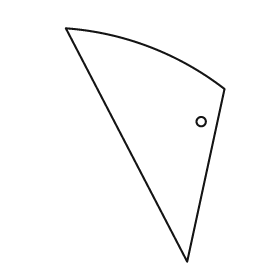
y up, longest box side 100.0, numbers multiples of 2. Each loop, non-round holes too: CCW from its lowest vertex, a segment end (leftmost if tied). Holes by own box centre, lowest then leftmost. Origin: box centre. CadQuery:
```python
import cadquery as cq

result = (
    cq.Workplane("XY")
    .moveTo(18.0, -50.0)
    .lineTo(34.0, 24.0)
    .threePointArc((2.0, 42.0), (-34.0, 50.0))
    .close()
    .moveTo(24.0, 10.0)
    .circle(2.0)
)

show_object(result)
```